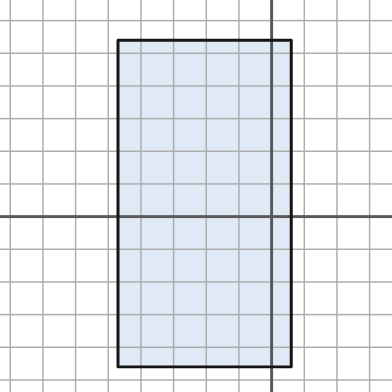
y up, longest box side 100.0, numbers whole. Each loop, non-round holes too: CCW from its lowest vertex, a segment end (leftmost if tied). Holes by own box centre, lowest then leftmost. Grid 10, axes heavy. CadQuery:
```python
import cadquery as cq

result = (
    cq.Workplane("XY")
    .moveTo(-47.0, -46.0)
    .lineTo(6.0, -46.0)
    .lineTo(6.0, 54.0)
    .lineTo(-47.0, 54.0)
    .close()
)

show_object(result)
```